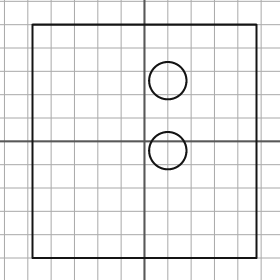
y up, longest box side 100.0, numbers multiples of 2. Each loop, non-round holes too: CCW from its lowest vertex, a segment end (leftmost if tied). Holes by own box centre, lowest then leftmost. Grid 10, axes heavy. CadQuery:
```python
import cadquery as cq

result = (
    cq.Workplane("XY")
    .moveTo(-48.0, -50.0)
    .lineTo(48.0, -50.0)
    .lineTo(48.0, 50.0)
    .lineTo(-48.0, 50.0)
    .close()
    .moveTo(10.0, -4.0)
    .circle(8.0)
    .moveTo(10.0, 26.0)
    .circle(8.0)
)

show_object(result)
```